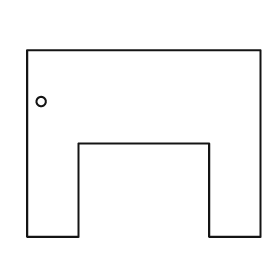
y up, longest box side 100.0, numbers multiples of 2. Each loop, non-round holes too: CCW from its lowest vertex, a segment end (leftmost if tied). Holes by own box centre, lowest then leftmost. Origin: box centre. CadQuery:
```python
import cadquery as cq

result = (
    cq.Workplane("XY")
    .moveTo(-50.0, -40.0)
    .lineTo(-28.0, -40.0)
    .lineTo(-28.0, 0.0)
    .lineTo(28.0, 0.0)
    .lineTo(28.0, -40.0)
    .lineTo(50.0, -40.0)
    .lineTo(50.0, 40.0)
    .lineTo(-50.0, 40.0)
    .close()
    .moveTo(-44.0, 18.0)
    .circle(2.0)
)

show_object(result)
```